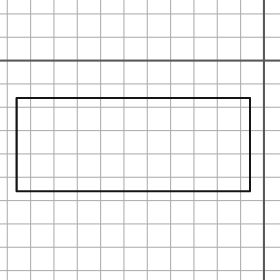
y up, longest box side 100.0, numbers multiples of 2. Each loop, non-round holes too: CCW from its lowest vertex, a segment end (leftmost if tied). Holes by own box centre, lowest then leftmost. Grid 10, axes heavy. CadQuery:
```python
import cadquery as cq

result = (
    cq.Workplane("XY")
    .moveTo(-106.0, -56.0)
    .lineTo(-6.0, -56.0)
    .lineTo(-6.0, -16.0)
    .lineTo(-106.0, -16.0)
    .close()
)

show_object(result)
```